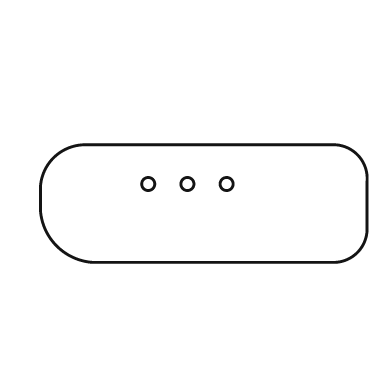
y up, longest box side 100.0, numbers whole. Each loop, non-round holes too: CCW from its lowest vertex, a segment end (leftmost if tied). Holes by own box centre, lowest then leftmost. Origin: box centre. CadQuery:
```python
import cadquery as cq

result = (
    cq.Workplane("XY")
    .moveTo(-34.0, -18.0)
    .lineTo(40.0, -18.0)
    .threePointArc((47.0, -15.0), (50.0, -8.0))
    .lineTo(50.0, 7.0)
    .threePointArc((47.0, 15.0), (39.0, 18.0))
    .lineTo(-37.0, 18.0)
    .threePointArc((-46.0, 14.0), (-50.0, 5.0))
    .lineTo(-50.0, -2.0)
    .threePointArc((-45.0, -13.0), (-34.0, -18.0))
    .close()
    .moveTo(-17.0, 6.0)
    .circle(2.0)
    .moveTo(-5.0, 6.0)
    .circle(2.0)
    .moveTo(7.0, 6.0)
    .circle(2.0)
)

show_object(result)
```